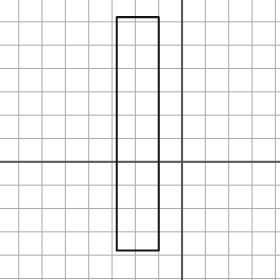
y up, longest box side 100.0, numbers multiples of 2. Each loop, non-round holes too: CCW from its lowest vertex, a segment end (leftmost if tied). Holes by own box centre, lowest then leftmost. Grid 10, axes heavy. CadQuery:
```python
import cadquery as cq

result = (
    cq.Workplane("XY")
    .moveTo(-28.0, -38.0)
    .lineTo(-10.0, -38.0)
    .lineTo(-10.0, 62.0)
    .lineTo(-28.0, 62.0)
    .close()
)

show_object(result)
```